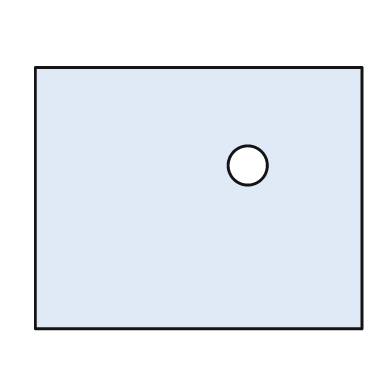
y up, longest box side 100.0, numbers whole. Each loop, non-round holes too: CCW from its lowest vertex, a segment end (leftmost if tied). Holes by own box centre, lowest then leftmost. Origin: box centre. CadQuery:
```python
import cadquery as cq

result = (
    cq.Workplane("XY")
    .moveTo(-50.0, -40.0)
    .lineTo(50.0, -40.0)
    .lineTo(50.0, 40.0)
    .lineTo(-50.0, 40.0)
    .close()
    .moveTo(15.0, 10.0)
    .circle(6.0)
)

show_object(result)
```